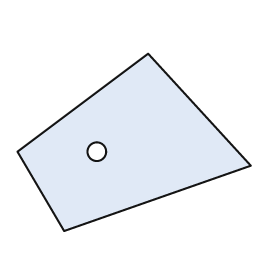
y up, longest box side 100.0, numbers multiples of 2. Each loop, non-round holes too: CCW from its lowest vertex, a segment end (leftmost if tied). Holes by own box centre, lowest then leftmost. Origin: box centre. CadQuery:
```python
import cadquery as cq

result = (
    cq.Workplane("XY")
    .moveTo(-30.0, -38.0)
    .lineTo(50.0, -10.0)
    .lineTo(6.0, 38.0)
    .lineTo(-50.0, -4.0)
    .close()
    .moveTo(-16.0, -4.0)
    .circle(4.0)
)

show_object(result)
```